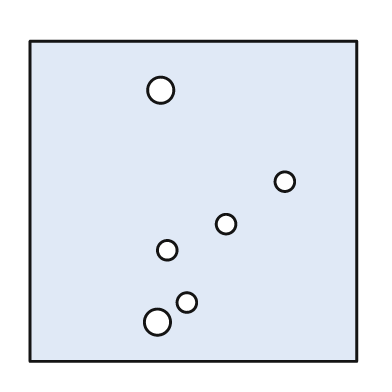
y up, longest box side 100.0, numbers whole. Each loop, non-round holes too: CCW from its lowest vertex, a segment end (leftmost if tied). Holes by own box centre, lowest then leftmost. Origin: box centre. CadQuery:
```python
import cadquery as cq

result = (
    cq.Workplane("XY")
    .moveTo(-50.0, -49.0)
    .lineTo(50.0, -49.0)
    .lineTo(50.0, 49.0)
    .lineTo(-50.0, 49.0)
    .close()
    .moveTo(-11.0, -37.0)
    .circle(4.0)
    .moveTo(-2.0, -31.0)
    .circle(3.0)
    .moveTo(-8.0, -15.0)
    .circle(3.0)
    .moveTo(10.0, -7.0)
    .circle(3.0)
    .moveTo(28.0, 6.0)
    .circle(3.0)
    .moveTo(-10.0, 34.0)
    .circle(4.0)
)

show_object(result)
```